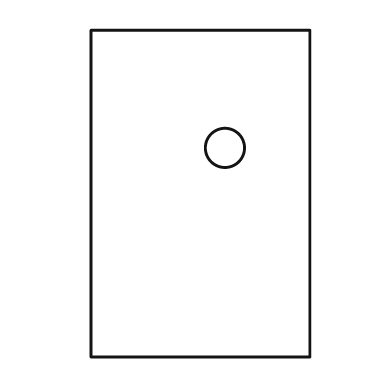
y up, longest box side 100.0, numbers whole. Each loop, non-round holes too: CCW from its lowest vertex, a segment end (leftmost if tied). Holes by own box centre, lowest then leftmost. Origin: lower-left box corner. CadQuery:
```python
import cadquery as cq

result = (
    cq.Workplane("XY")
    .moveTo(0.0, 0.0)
    .lineTo(67.0, 0.0)
    .lineTo(67.0, 100.0)
    .lineTo(0.0, 100.0)
    .close()
    .moveTo(41.0, 64.0)
    .circle(6.0)
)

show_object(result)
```